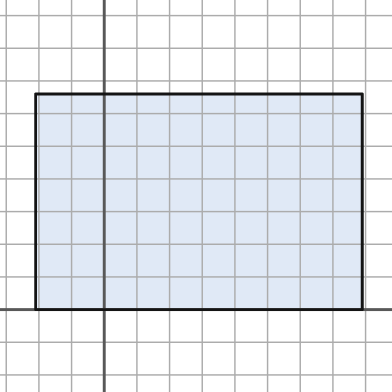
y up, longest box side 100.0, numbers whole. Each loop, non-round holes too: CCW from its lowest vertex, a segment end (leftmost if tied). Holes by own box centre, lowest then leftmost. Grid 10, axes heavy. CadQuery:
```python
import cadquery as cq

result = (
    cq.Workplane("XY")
    .moveTo(-21.0, 0.0)
    .lineTo(79.0, 0.0)
    .lineTo(79.0, 66.0)
    .lineTo(-21.0, 66.0)
    .close()
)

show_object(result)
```